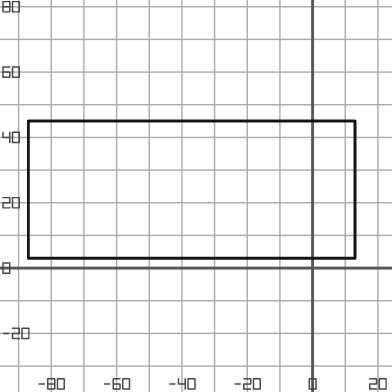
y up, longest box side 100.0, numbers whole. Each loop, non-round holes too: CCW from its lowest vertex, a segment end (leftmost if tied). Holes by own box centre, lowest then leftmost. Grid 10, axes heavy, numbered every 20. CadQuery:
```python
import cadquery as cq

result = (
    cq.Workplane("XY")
    .moveTo(-87.0, 3.0)
    .lineTo(13.0, 3.0)
    .lineTo(13.0, 45.0)
    .lineTo(-87.0, 45.0)
    .close()
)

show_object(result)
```